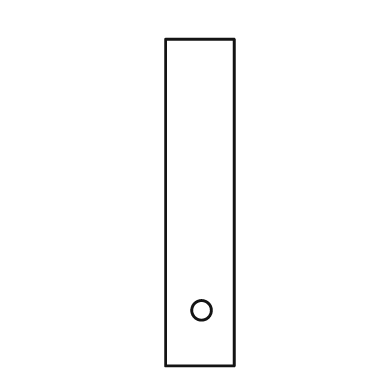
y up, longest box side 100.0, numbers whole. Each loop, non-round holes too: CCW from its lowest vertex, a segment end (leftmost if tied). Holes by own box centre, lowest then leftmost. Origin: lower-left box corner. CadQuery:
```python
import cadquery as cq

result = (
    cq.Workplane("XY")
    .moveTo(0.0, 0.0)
    .lineTo(21.0, 0.0)
    .lineTo(21.0, 100.0)
    .lineTo(0.0, 100.0)
    .close()
    .moveTo(11.0, 17.0)
    .circle(3.0)
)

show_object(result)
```